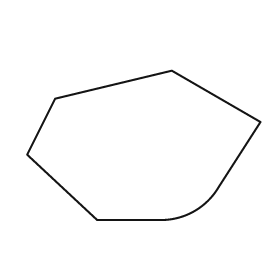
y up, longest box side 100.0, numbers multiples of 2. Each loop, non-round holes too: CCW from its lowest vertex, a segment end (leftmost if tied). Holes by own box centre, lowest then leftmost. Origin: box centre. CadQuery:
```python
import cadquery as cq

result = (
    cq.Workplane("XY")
    .moveTo(-20.0, -32.0)
    .lineTo(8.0, -32.0)
    .threePointArc((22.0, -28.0), (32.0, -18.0))
    .lineTo(50.0, 10.0)
    .lineTo(12.0, 32.0)
    .lineTo(-38.0, 20.0)
    .lineTo(-50.0, -4.0)
    .close()
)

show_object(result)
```